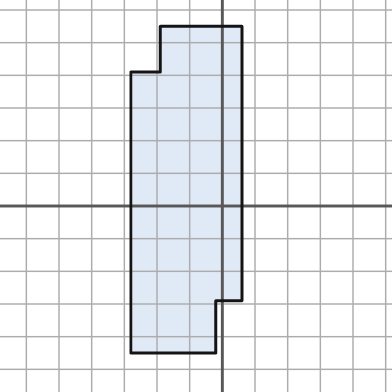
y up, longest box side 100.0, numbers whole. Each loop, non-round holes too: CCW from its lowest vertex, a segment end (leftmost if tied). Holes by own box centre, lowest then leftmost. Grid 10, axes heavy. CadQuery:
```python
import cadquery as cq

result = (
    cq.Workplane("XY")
    .moveTo(-28.0, -45.0)
    .lineTo(-2.0, -45.0)
    .lineTo(-2.0, -29.0)
    .lineTo(6.0, -29.0)
    .lineTo(6.0, 55.0)
    .lineTo(-19.0, 55.0)
    .lineTo(-19.0, 41.0)
    .lineTo(-28.0, 41.0)
    .close()
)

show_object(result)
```